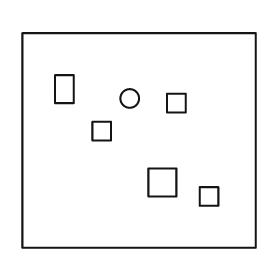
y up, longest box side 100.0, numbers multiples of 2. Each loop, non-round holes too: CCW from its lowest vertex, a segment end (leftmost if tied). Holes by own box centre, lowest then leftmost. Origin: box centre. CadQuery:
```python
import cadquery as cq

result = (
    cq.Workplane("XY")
    .moveTo(-50.0, -46.0)
    .lineTo(50.0, -46.0)
    .lineTo(50.0, 46.0)
    .lineTo(-50.0, 46.0)
    .close()
    .moveTo(26.0, -28.0)
    .lineTo(34.0, -28.0)
    .lineTo(34.0, -20.0)
    .lineTo(26.0, -20.0)
    .close()
    .moveTo(4.0, -24.0)
    .lineTo(16.0, -24.0)
    .lineTo(16.0, -12.0)
    .lineTo(4.0, -12.0)
    .close()
    .moveTo(-20.0, 0.0)
    .lineTo(-12.0, 0.0)
    .lineTo(-12.0, 8.0)
    .lineTo(-20.0, 8.0)
    .close()
    .moveTo(12.0, 12.0)
    .lineTo(20.0, 12.0)
    .lineTo(20.0, 20.0)
    .lineTo(12.0, 20.0)
    .close()
    .moveTo(-4.0, 18.0)
    .circle(4.0)
    .moveTo(-36.0, 16.0)
    .lineTo(-28.0, 16.0)
    .lineTo(-28.0, 28.0)
    .lineTo(-36.0, 28.0)
    .close()
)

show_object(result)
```